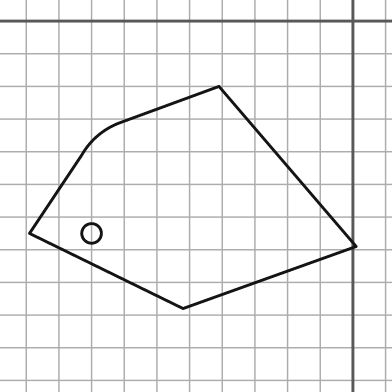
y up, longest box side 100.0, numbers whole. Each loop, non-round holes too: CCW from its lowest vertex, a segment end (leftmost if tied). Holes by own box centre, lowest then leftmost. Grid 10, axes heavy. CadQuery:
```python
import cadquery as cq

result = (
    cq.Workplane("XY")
    .moveTo(-52.0, -88.0)
    .lineTo(1.0, -69.0)
    .lineTo(-41.0, -20.0)
    .lineTo(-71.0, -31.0)
    .threePointArc((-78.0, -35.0), (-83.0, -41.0))
    .lineTo(-99.0, -65.0)
    .close()
    .moveTo(-80.0, -65.0)
    .circle(3.0)
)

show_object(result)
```